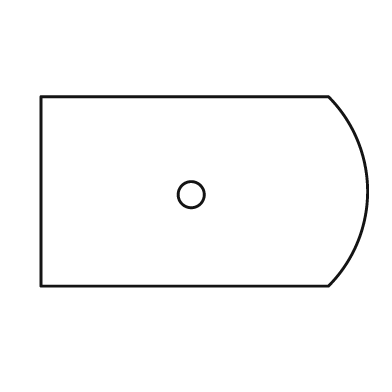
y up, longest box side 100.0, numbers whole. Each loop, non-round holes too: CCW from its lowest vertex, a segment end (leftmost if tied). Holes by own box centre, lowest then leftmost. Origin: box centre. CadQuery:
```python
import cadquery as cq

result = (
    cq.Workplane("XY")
    .moveTo(-50.0, -29.0)
    .lineTo(38.0, -29.0)
    .threePointArc((50.0, 0.0), (38.0, 29.0))
    .lineTo(-50.0, 29.0)
    .close()
    .moveTo(-4.0, -1.0)
    .circle(4.0)
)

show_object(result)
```